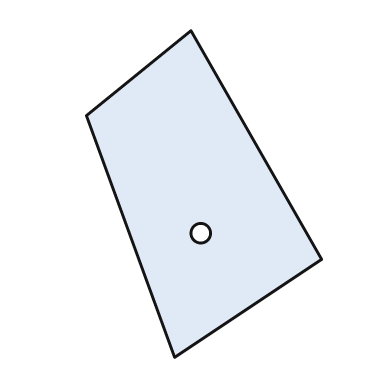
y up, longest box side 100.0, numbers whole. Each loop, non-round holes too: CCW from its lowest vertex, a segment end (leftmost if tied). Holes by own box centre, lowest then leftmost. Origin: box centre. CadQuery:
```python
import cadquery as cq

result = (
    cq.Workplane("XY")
    .moveTo(-9.0, -50.0)
    .lineTo(36.0, -20.0)
    .lineTo(-4.0, 50.0)
    .lineTo(-36.0, 24.0)
    .close()
    .moveTo(-1.0, -12.0)
    .circle(3.0)
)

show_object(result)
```